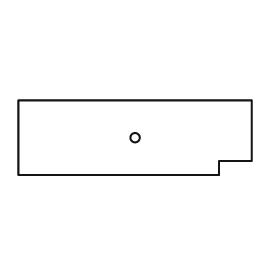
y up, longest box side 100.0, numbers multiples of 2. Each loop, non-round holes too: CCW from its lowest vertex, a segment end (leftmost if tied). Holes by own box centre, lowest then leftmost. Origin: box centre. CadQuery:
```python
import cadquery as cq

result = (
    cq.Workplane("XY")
    .moveTo(-50.0, -16.0)
    .lineTo(36.0, -16.0)
    .lineTo(36.0, -10.0)
    .lineTo(50.0, -10.0)
    .lineTo(50.0, 16.0)
    .lineTo(-50.0, 16.0)
    .close()
    .moveTo(0.0, 0.0)
    .circle(2.0)
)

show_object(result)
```